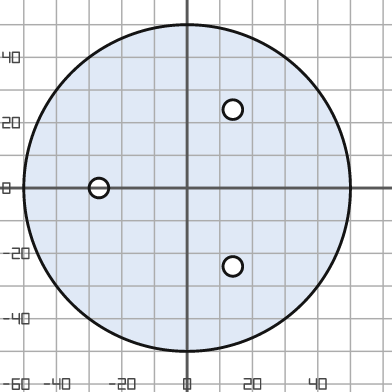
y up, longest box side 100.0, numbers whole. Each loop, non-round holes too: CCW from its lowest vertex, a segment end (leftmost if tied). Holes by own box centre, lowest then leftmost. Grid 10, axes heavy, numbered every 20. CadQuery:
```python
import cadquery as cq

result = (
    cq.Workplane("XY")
    .moveTo(0.0, 0.0)
    .circle(50.0)
    .moveTo(14.0, -24.0)
    .circle(3.0)
    .moveTo(-27.0, 0.0)
    .circle(3.0)
    .moveTo(14.0, 24.0)
    .circle(3.0)
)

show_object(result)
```